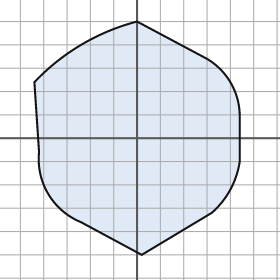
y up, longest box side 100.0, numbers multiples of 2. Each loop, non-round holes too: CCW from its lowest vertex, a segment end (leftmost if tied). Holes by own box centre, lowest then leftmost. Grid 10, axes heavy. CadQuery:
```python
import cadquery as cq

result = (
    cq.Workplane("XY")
    .moveTo(2.0, -50.0)
    .lineTo(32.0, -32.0)
    .threePointArc((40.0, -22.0), (44.0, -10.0))
    .lineTo(44.0, 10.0)
    .threePointArc((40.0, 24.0), (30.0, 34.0))
    .lineTo(0.0, 50.0)
    .threePointArc((-24.0, 40.0), (-44.0, 24.0))
    .lineTo(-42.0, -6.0)
    .threePointArc((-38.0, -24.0), (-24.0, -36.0))
    .close()
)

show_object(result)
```